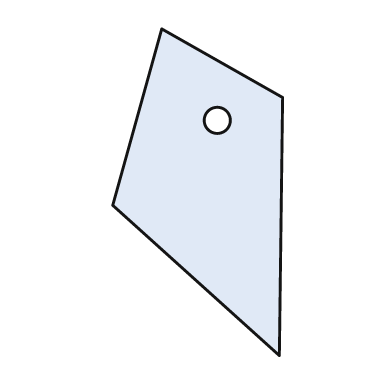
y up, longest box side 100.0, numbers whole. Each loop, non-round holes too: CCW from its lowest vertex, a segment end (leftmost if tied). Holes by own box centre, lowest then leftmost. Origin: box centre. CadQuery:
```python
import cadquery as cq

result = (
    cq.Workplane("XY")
    .moveTo(25.0, -50.0)
    .lineTo(26.0, 29.0)
    .lineTo(-11.0, 50.0)
    .lineTo(-26.0, -4.0)
    .close()
    .moveTo(6.0, 22.0)
    .circle(4.0)
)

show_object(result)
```